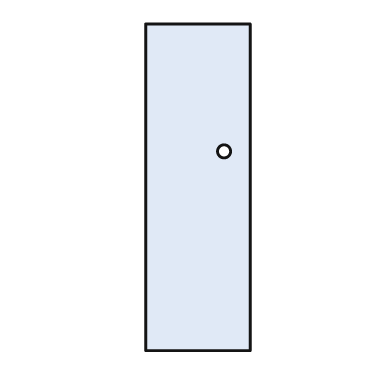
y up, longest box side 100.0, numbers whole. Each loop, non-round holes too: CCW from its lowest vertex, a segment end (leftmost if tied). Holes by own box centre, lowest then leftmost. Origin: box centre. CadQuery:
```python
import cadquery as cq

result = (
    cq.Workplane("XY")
    .moveTo(-16.0, -50.0)
    .lineTo(16.0, -50.0)
    .lineTo(16.0, 50.0)
    .lineTo(-16.0, 50.0)
    .close()
    .moveTo(8.0, 11.0)
    .circle(2.0)
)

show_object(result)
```